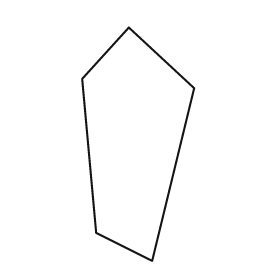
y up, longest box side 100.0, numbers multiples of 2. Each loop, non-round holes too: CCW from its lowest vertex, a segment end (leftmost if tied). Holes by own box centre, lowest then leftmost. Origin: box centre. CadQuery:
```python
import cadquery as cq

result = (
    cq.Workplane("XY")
    .moveTo(6.0, -50.0)
    .lineTo(24.0, 24.0)
    .lineTo(-4.0, 50.0)
    .lineTo(-24.0, 28.0)
    .lineTo(-18.0, -38.0)
    .close()
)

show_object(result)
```